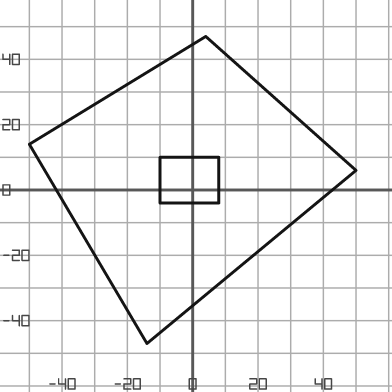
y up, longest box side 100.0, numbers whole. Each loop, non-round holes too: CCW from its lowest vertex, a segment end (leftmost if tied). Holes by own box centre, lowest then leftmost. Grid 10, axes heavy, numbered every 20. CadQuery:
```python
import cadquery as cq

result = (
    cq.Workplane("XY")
    .moveTo(-14.0, -47.0)
    .lineTo(50.0, 6.0)
    .lineTo(4.0, 47.0)
    .lineTo(-50.0, 14.0)
    .close()
    .moveTo(-10.0, -4.0)
    .lineTo(8.0, -4.0)
    .lineTo(8.0, 10.0)
    .lineTo(-10.0, 10.0)
    .close()
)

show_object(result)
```